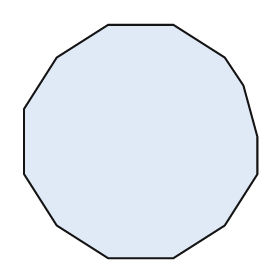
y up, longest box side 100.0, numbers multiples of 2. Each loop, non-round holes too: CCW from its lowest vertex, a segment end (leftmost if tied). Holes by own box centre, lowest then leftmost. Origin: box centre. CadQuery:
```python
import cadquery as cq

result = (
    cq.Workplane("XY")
    .moveTo(-14.0, -50.0)
    .lineTo(14.0, -50.0)
    .lineTo(36.0, -36.0)
    .lineTo(50.0, -14.0)
    .lineTo(50.0, 2.0)
    .lineTo(44.0, 24.0)
    .lineTo(36.0, 36.0)
    .lineTo(14.0, 50.0)
    .lineTo(-14.0, 50.0)
    .lineTo(-36.0, 36.0)
    .lineTo(-50.0, 14.0)
    .lineTo(-50.0, -14.0)
    .lineTo(-36.0, -36.0)
    .close()
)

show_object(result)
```